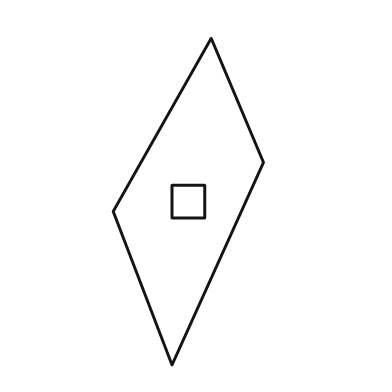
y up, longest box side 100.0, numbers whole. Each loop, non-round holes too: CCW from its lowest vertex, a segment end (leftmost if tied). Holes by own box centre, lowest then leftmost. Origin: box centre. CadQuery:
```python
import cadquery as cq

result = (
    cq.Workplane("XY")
    .moveTo(-5.0, -50.0)
    .lineTo(23.0, 12.0)
    .lineTo(7.0, 50.0)
    .lineTo(-23.0, -3.0)
    .close()
    .moveTo(-5.0, -5.0)
    .lineTo(5.0, -5.0)
    .lineTo(5.0, 5.0)
    .lineTo(-5.0, 5.0)
    .close()
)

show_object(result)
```